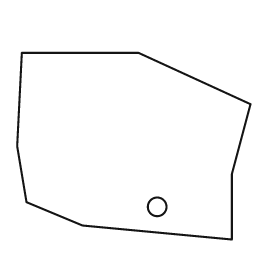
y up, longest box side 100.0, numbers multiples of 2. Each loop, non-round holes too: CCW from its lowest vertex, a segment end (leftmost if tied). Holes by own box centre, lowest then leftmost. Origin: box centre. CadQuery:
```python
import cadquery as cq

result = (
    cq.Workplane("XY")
    .moveTo(42.0, -40.0)
    .lineTo(42.0, -12.0)
    .lineTo(50.0, 18.0)
    .lineTo(2.0, 40.0)
    .lineTo(-48.0, 40.0)
    .lineTo(-50.0, 0.0)
    .lineTo(-46.0, -24.0)
    .lineTo(-22.0, -34.0)
    .close()
    .moveTo(10.0, -26.0)
    .circle(4.0)
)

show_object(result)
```